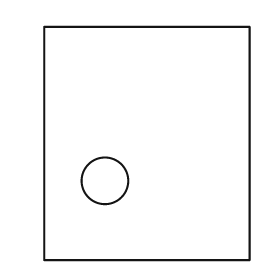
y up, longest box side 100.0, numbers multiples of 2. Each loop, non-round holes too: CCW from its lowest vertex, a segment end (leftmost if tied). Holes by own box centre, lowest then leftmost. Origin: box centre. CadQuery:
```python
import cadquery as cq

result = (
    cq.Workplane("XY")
    .moveTo(-44.0, -50.0)
    .lineTo(44.0, -50.0)
    .lineTo(44.0, 50.0)
    .lineTo(-44.0, 50.0)
    .close()
    .moveTo(-18.0, -16.0)
    .circle(10.0)
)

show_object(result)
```